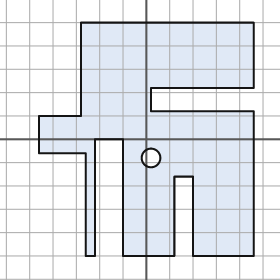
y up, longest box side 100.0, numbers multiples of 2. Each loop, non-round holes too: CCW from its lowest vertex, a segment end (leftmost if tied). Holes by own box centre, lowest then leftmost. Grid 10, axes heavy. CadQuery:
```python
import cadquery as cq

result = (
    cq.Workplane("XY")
    .moveTo(-26.0, -50.0)
    .lineTo(-22.0, -50.0)
    .lineTo(-22.0, 0.0)
    .lineTo(-10.0, 0.0)
    .lineTo(-10.0, -50.0)
    .lineTo(12.0, -50.0)
    .lineTo(12.0, -16.0)
    .lineTo(20.0, -16.0)
    .lineTo(20.0, -50.0)
    .lineTo(46.0, -50.0)
    .lineTo(46.0, 12.0)
    .lineTo(2.0, 12.0)
    .lineTo(2.0, 22.0)
    .lineTo(46.0, 22.0)
    .lineTo(46.0, 50.0)
    .lineTo(-28.0, 50.0)
    .lineTo(-28.0, 10.0)
    .lineTo(-46.0, 10.0)
    .lineTo(-46.0, -6.0)
    .lineTo(-26.0, -6.0)
    .close()
    .moveTo(2.0, -8.0)
    .circle(4.0)
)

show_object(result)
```